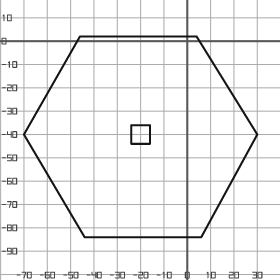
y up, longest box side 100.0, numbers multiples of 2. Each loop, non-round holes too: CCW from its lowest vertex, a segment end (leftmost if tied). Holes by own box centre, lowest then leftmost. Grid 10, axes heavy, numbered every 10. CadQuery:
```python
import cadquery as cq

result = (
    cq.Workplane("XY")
    .moveTo(-44.0, -84.0)
    .lineTo(6.0, -84.0)
    .lineTo(30.0, -40.0)
    .lineTo(4.0, 2.0)
    .lineTo(-46.0, 2.0)
    .lineTo(-70.0, -40.0)
    .close()
    .moveTo(-24.0, -44.0)
    .lineTo(-16.0, -44.0)
    .lineTo(-16.0, -36.0)
    .lineTo(-24.0, -36.0)
    .close()
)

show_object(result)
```